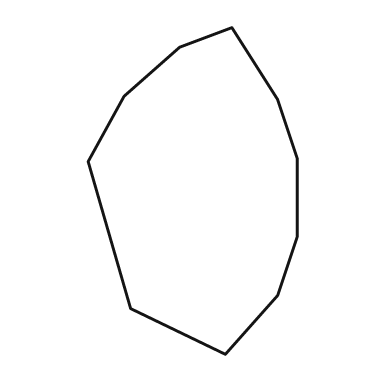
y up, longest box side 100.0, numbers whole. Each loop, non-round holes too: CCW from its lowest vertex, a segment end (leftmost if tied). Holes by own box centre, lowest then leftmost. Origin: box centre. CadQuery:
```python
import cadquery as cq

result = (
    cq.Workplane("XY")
    .moveTo(10.0, -50.0)
    .lineTo(26.0, -32.0)
    .lineTo(32.0, -14.0)
    .lineTo(32.0, 10.0)
    .lineTo(26.0, 28.0)
    .lineTo(12.0, 50.0)
    .lineTo(-4.0, 44.0)
    .lineTo(-21.0, 29.0)
    .lineTo(-32.0, 9.0)
    .lineTo(-19.0, -36.0)
    .close()
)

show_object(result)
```